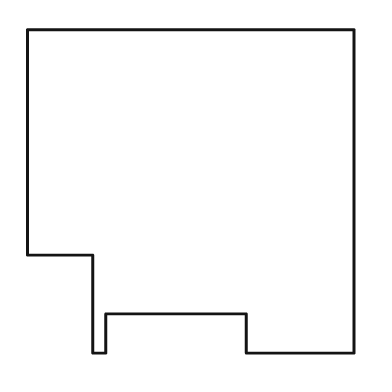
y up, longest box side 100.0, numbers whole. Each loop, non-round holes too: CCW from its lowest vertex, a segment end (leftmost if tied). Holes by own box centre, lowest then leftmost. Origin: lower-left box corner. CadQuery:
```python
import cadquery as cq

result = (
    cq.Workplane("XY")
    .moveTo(20.0, 0.0)
    .lineTo(24.0, 0.0)
    .lineTo(24.0, 12.0)
    .lineTo(67.0, 12.0)
    .lineTo(67.0, 0.0)
    .lineTo(100.0, 0.0)
    .lineTo(100.0, 99.0)
    .lineTo(0.0, 99.0)
    .lineTo(0.0, 30.0)
    .lineTo(20.0, 30.0)
    .close()
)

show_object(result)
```